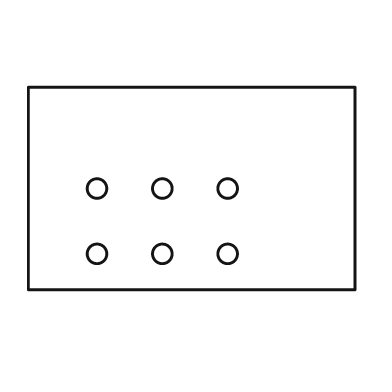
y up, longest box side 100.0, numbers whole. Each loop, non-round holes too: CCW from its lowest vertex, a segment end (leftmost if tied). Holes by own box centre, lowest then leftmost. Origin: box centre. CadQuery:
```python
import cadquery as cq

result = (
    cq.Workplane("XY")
    .moveTo(-50.0, -31.0)
    .lineTo(50.0, -31.0)
    .lineTo(50.0, 31.0)
    .lineTo(-50.0, 31.0)
    .close()
    .moveTo(-29.0, -20.0)
    .circle(3.0)
    .moveTo(-9.0, -20.0)
    .circle(3.0)
    .moveTo(11.0, -20.0)
    .circle(3.0)
    .moveTo(-29.0, 0.0)
    .circle(3.0)
    .moveTo(-9.0, 0.0)
    .circle(3.0)
    .moveTo(11.0, 0.0)
    .circle(3.0)
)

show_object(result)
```